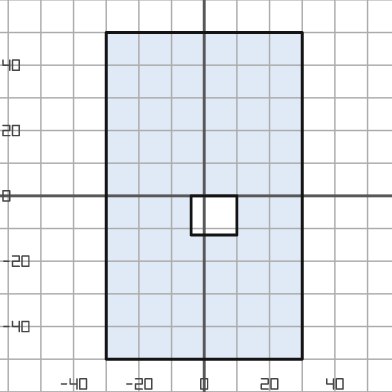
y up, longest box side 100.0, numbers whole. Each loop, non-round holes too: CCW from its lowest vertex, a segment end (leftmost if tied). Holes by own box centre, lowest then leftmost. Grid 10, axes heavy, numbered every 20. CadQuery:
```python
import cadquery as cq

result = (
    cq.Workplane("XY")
    .moveTo(-30.0, -50.0)
    .lineTo(30.0, -50.0)
    .lineTo(30.0, 50.0)
    .lineTo(-30.0, 50.0)
    .close()
    .moveTo(-4.0, -12.0)
    .lineTo(10.0, -12.0)
    .lineTo(10.0, 0.0)
    .lineTo(-4.0, 0.0)
    .close()
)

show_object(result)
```